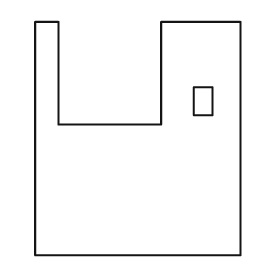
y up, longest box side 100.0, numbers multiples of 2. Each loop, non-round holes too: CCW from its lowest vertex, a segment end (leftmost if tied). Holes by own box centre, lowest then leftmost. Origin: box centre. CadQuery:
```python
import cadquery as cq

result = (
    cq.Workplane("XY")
    .moveTo(-44.0, -50.0)
    .lineTo(44.0, -50.0)
    .lineTo(44.0, 50.0)
    .lineTo(10.0, 50.0)
    .lineTo(10.0, 6.0)
    .lineTo(-34.0, 6.0)
    .lineTo(-34.0, 50.0)
    .lineTo(-44.0, 50.0)
    .close()
    .moveTo(24.0, 10.0)
    .lineTo(32.0, 10.0)
    .lineTo(32.0, 22.0)
    .lineTo(24.0, 22.0)
    .close()
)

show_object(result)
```